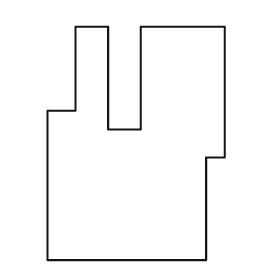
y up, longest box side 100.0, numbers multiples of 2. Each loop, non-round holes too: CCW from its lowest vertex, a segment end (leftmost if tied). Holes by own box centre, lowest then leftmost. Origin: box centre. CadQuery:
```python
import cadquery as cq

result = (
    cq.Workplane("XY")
    .moveTo(-38.0, -50.0)
    .lineTo(30.0, -50.0)
    .lineTo(30.0, -6.0)
    .lineTo(38.0, -6.0)
    .lineTo(38.0, 50.0)
    .lineTo(2.0, 50.0)
    .lineTo(2.0, 6.0)
    .lineTo(-12.0, 6.0)
    .lineTo(-12.0, 50.0)
    .lineTo(-26.0, 50.0)
    .lineTo(-26.0, 14.0)
    .lineTo(-38.0, 14.0)
    .close()
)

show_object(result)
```